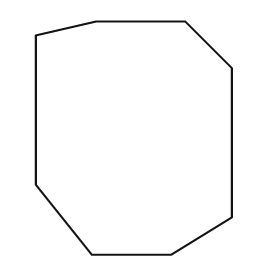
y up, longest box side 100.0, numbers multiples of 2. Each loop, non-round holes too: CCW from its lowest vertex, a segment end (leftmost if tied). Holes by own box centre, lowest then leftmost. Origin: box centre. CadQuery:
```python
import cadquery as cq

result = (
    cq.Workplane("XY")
    .moveTo(-18.0, -50.0)
    .lineTo(16.0, -50.0)
    .lineTo(42.0, -34.0)
    .lineTo(42.0, 30.0)
    .lineTo(22.0, 50.0)
    .lineTo(-16.0, 50.0)
    .lineTo(-42.0, 44.0)
    .lineTo(-42.0, -20.0)
    .close()
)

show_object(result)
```